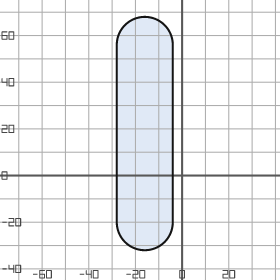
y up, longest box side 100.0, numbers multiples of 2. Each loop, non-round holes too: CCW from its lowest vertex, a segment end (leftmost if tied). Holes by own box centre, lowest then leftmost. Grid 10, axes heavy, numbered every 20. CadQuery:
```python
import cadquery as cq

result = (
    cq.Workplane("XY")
    .moveTo(-28.0, -20.0)
    .threePointArc((-16.0, -32.0), (-4.0, -20.0))
    .lineTo(-4.0, 56.0)
    .threePointArc((-16.0, 68.0), (-28.0, 56.0))
    .close()
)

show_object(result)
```